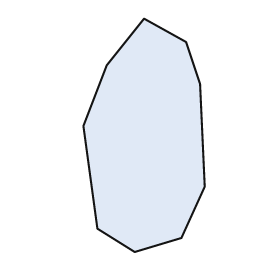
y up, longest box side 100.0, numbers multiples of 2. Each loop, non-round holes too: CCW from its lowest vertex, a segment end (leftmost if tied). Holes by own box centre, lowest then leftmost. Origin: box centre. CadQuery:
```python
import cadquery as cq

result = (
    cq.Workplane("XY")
    .moveTo(-4.0, -50.0)
    .lineTo(16.0, -44.0)
    .lineTo(26.0, -22.0)
    .lineTo(24.0, 22.0)
    .lineTo(18.0, 40.0)
    .lineTo(0.0, 50.0)
    .lineTo(-16.0, 30.0)
    .lineTo(-26.0, 4.0)
    .lineTo(-20.0, -40.0)
    .close()
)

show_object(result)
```